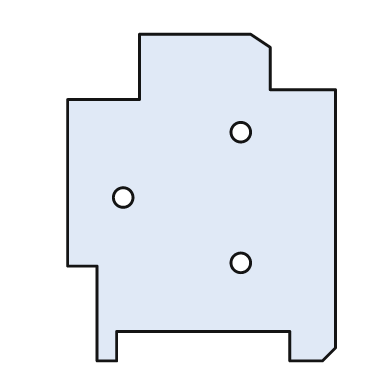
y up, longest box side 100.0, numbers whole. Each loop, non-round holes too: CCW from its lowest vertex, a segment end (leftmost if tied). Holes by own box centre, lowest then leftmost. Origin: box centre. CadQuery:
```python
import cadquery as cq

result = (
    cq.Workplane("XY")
    .moveTo(-32.0, -50.0)
    .lineTo(-26.0, -50.0)
    .lineTo(-26.0, -41.0)
    .lineTo(27.0, -41.0)
    .lineTo(27.0, -50.0)
    .lineTo(37.0, -50.0)
    .lineTo(41.0, -46.0)
    .lineTo(41.0, 33.0)
    .lineTo(21.0, 33.0)
    .lineTo(21.0, 46.0)
    .lineTo(15.0, 50.0)
    .lineTo(-19.0, 50.0)
    .lineTo(-19.0, 30.0)
    .lineTo(-41.0, 30.0)
    .lineTo(-41.0, -21.0)
    .lineTo(-32.0, -21.0)
    .close()
    .moveTo(12.0, -20.0)
    .circle(3.0)
    .moveTo(-24.0, 0.0)
    .circle(3.0)
    .moveTo(12.0, 20.0)
    .circle(3.0)
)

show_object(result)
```